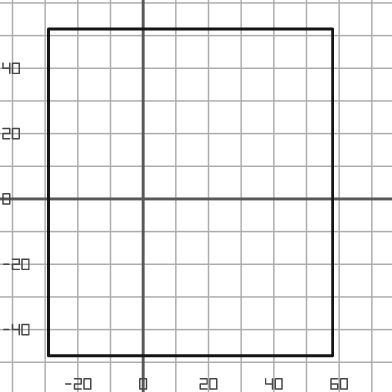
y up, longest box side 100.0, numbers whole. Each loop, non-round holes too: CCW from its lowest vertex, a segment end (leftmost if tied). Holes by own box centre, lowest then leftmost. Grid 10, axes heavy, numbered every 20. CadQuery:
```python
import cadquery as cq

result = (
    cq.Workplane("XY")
    .moveTo(-29.0, -48.0)
    .lineTo(58.0, -48.0)
    .lineTo(58.0, 52.0)
    .lineTo(-29.0, 52.0)
    .close()
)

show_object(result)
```